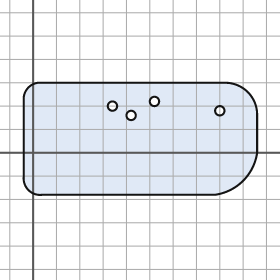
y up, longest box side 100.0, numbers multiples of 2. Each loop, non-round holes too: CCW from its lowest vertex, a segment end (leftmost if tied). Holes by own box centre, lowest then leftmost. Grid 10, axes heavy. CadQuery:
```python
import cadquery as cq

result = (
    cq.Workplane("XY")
    .moveTo(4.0, -18.0)
    .lineTo(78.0, -18.0)
    .threePointArc((90.0, -12.0), (96.0, 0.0))
    .lineTo(96.0, 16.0)
    .threePointArc((92.0, 26.0), (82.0, 30.0))
    .lineTo(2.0, 30.0)
    .threePointArc((-2.0, 28.0), (-4.0, 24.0))
    .lineTo(-4.0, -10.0)
    .threePointArc((-2.0, -16.0), (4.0, -18.0))
    .close()
    .moveTo(42.0, 16.0)
    .circle(2.0)
    .moveTo(80.0, 18.0)
    .circle(2.0)
    .moveTo(34.0, 20.0)
    .circle(2.0)
    .moveTo(52.0, 22.0)
    .circle(2.0)
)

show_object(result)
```